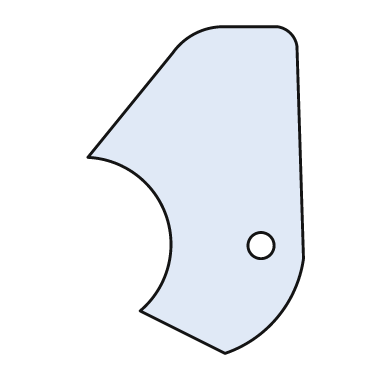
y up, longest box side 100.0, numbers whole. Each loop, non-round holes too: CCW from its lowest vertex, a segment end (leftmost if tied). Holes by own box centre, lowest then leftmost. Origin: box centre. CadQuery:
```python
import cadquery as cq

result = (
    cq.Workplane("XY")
    .moveTo(9.0, -50.0)
    .threePointArc((25.0, -39.0), (33.0, -21.0))
    .lineTo(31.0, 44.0)
    .threePointArc((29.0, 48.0), (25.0, 50.0))
    .lineTo(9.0, 50.0)
    .threePointArc((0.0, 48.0), (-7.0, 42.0))
    .lineTo(-33.0, 10.0)
    .threePointArc((-9.0, -8.0), (-17.0, -37.0))
    .close()
    .moveTo(20.0, -17.0)
    .circle(4.0)
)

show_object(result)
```